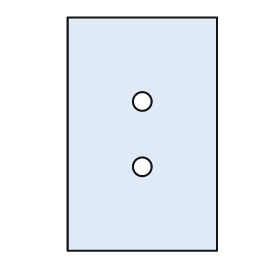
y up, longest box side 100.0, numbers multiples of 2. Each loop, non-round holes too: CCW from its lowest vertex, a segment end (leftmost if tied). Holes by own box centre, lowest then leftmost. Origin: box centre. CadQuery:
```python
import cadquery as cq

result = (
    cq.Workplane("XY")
    .moveTo(-32.0, -50.0)
    .lineTo(32.0, -50.0)
    .lineTo(32.0, 50.0)
    .lineTo(-32.0, 50.0)
    .close()
    .moveTo(0.0, -14.0)
    .circle(4.0)
    .moveTo(0.0, 14.0)
    .circle(4.0)
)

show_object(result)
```